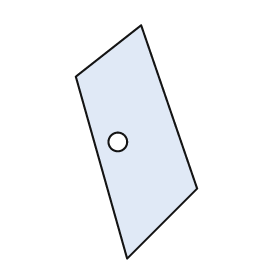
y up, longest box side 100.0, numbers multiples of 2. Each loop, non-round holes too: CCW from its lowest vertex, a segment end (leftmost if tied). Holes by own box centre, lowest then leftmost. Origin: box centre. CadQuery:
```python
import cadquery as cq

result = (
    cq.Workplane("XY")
    .moveTo(-4.0, -50.0)
    .lineTo(26.0, -20.0)
    .lineTo(2.0, 50.0)
    .lineTo(-26.0, 28.0)
    .close()
    .moveTo(-8.0, 0.0)
    .circle(4.0)
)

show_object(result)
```